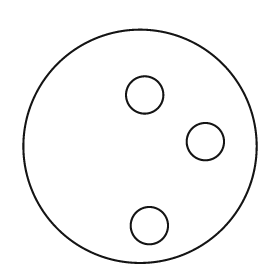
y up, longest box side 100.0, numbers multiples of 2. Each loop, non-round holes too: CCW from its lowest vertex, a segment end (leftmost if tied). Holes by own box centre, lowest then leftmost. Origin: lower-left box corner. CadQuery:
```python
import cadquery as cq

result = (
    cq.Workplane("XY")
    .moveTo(50.0, 50.0)
    .circle(50.0)
    .moveTo(54.0, 16.0)
    .circle(8.0)
    .moveTo(78.0, 52.0)
    .circle(8.0)
    .moveTo(52.0, 72.0)
    .circle(8.0)
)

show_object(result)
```